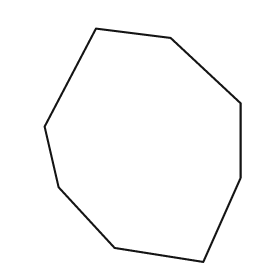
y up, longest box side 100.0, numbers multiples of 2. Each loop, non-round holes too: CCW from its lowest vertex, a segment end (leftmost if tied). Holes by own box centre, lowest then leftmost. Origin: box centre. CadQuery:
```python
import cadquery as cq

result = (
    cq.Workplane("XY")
    .moveTo(26.0, -50.0)
    .lineTo(42.0, -14.0)
    .lineTo(42.0, 18.0)
    .lineTo(12.0, 46.0)
    .lineTo(-20.0, 50.0)
    .lineTo(-42.0, 8.0)
    .lineTo(-36.0, -18.0)
    .lineTo(-12.0, -44.0)
    .close()
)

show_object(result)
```